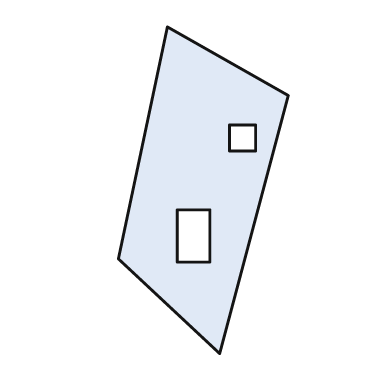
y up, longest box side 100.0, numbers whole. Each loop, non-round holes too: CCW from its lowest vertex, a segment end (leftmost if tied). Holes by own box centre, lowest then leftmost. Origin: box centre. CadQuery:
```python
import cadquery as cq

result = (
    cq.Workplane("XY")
    .moveTo(5.0, -50.0)
    .lineTo(26.0, 29.0)
    .lineTo(-11.0, 50.0)
    .lineTo(-26.0, -21.0)
    .close()
    .moveTo(-8.0, -22.0)
    .lineTo(2.0, -22.0)
    .lineTo(2.0, -6.0)
    .lineTo(-8.0, -6.0)
    .close()
    .moveTo(8.0, 12.0)
    .lineTo(16.0, 12.0)
    .lineTo(16.0, 20.0)
    .lineTo(8.0, 20.0)
    .close()
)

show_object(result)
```